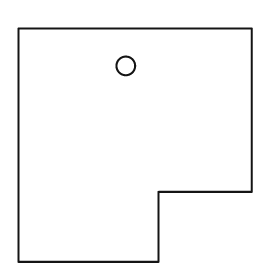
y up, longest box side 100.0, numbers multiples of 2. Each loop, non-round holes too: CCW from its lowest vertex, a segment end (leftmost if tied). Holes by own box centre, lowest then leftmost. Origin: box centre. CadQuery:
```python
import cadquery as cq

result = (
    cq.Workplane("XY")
    .moveTo(-50.0, -50.0)
    .lineTo(10.0, -50.0)
    .lineTo(10.0, -20.0)
    .lineTo(50.0, -20.0)
    .lineTo(50.0, 50.0)
    .lineTo(-50.0, 50.0)
    .close()
    .moveTo(-4.0, 34.0)
    .circle(4.0)
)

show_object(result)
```